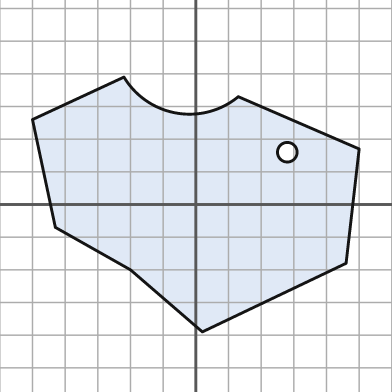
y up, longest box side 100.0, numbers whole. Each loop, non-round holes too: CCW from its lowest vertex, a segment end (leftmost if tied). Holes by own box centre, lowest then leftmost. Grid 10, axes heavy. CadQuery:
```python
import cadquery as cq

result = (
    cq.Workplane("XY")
    .moveTo(2.0, -39.0)
    .lineTo(46.0, -18.0)
    .lineTo(50.0, 17.0)
    .lineTo(13.0, 33.0)
    .threePointArc((-6.0, 28.0), (-22.0, 39.0))
    .lineTo(-50.0, 26.0)
    .lineTo(-43.0, -7.0)
    .lineTo(-20.0, -20.0)
    .close()
    .moveTo(28.0, 16.0)
    .circle(3.0)
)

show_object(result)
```